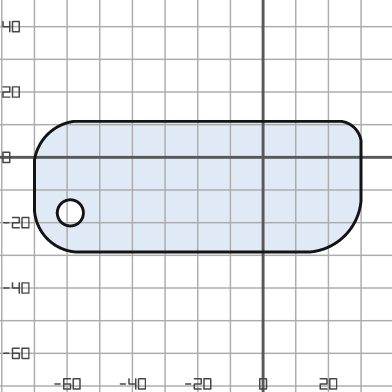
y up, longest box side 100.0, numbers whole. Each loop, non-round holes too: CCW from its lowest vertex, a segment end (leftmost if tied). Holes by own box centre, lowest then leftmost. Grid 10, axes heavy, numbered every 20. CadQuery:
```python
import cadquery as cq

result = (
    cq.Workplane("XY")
    .moveTo(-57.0, -29.0)
    .lineTo(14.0, -29.0)
    .threePointArc((25.0, -24.0), (30.0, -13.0))
    .lineTo(30.0, 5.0)
    .threePointArc((28.0, 9.0), (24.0, 11.0))
    .lineTo(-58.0, 11.0)
    .threePointArc((-66.0, 7.0), (-70.0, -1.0))
    .lineTo(-70.0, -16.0)
    .threePointArc((-66.0, -25.0), (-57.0, -29.0))
    .close()
    .moveTo(-59.0, -17.0)
    .circle(4.0)
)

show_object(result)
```